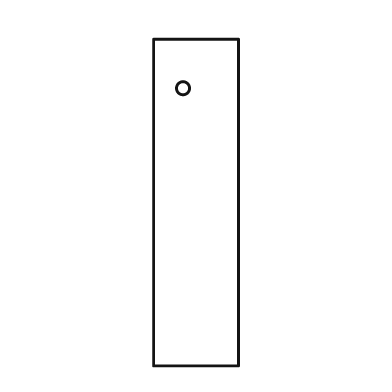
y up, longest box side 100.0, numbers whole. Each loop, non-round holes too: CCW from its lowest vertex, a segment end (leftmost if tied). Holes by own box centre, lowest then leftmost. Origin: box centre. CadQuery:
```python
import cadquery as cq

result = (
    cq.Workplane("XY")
    .moveTo(-13.0, -50.0)
    .lineTo(13.0, -50.0)
    .lineTo(13.0, 50.0)
    .lineTo(-13.0, 50.0)
    .close()
    .moveTo(-4.0, 35.0)
    .circle(2.0)
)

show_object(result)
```